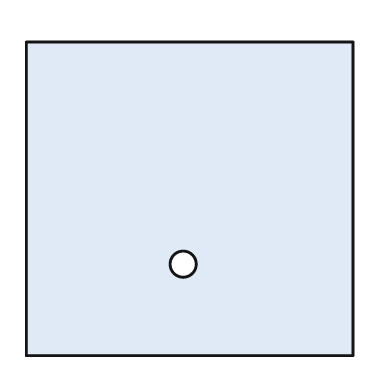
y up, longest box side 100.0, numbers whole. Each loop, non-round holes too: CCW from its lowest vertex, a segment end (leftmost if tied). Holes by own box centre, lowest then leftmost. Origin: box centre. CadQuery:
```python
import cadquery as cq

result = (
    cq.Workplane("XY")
    .moveTo(-50.0, -48.0)
    .lineTo(50.0, -48.0)
    .lineTo(50.0, 48.0)
    .lineTo(-50.0, 48.0)
    .close()
    .moveTo(-2.0, -20.0)
    .circle(4.0)
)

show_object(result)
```